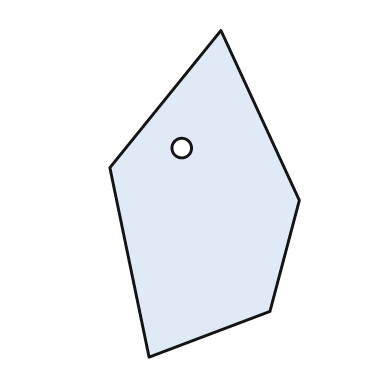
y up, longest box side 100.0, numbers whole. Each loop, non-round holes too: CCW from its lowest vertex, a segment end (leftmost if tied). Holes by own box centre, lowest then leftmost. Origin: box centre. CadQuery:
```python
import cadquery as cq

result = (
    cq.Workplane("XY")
    .moveTo(-17.0, -50.0)
    .lineTo(20.0, -36.0)
    .lineTo(29.0, -2.0)
    .lineTo(5.0, 50.0)
    .lineTo(-29.0, 8.0)
    .close()
    .moveTo(-7.0, 14.0)
    .circle(3.0)
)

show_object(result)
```